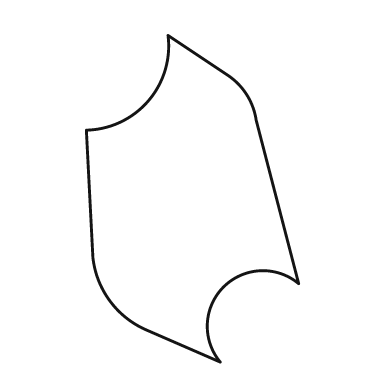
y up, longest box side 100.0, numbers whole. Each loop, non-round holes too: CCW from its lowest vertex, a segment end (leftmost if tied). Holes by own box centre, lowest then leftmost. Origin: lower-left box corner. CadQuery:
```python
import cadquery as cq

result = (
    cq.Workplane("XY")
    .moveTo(41.0, 0.0)
    .threePointArc((42.0, 23.0), (65.0, 24.0))
    .lineTo(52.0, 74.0)
    .threePointArc((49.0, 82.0), (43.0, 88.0))
    .lineTo(25.0, 100.0)
    .threePointArc((19.0, 80.0), (0.0, 71.0))
    .lineTo(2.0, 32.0)
    .threePointArc((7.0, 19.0), (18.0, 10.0))
    .close()
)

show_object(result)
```